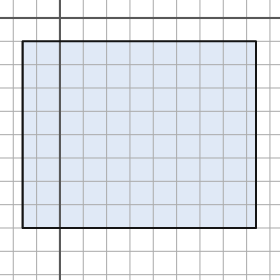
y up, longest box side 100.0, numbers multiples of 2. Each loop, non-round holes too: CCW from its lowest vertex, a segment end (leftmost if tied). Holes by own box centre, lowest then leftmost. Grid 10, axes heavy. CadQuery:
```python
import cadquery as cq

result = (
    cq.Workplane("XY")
    .moveTo(-16.0, -90.0)
    .lineTo(84.0, -90.0)
    .lineTo(84.0, -10.0)
    .lineTo(-16.0, -10.0)
    .close()
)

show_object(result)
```